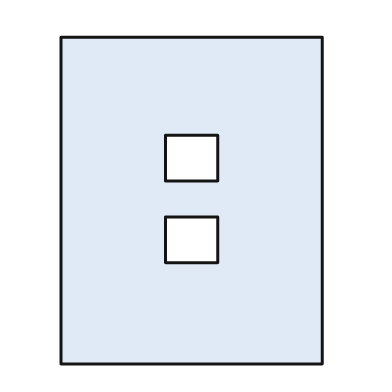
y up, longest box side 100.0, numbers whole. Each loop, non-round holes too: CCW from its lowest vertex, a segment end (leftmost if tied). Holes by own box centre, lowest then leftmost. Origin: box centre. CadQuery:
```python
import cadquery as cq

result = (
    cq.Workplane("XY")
    .moveTo(-40.0, -50.0)
    .lineTo(40.0, -50.0)
    .lineTo(40.0, 50.0)
    .lineTo(-40.0, 50.0)
    .close()
    .moveTo(-8.0, -19.0)
    .lineTo(8.0, -19.0)
    .lineTo(8.0, -5.0)
    .lineTo(-8.0, -5.0)
    .close()
    .moveTo(-8.0, 6.0)
    .lineTo(8.0, 6.0)
    .lineTo(8.0, 20.0)
    .lineTo(-8.0, 20.0)
    .close()
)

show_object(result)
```